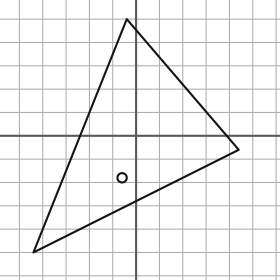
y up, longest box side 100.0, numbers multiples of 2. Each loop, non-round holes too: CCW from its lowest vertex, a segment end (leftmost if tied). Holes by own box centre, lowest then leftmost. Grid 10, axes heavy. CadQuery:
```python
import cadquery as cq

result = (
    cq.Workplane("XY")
    .moveTo(-44.0, -50.0)
    .lineTo(44.0, -6.0)
    .lineTo(-4.0, 50.0)
    .close()
    .moveTo(-6.0, -18.0)
    .circle(2.0)
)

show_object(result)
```